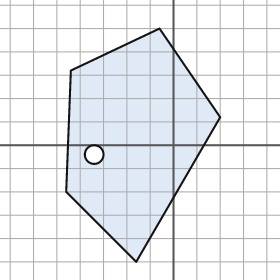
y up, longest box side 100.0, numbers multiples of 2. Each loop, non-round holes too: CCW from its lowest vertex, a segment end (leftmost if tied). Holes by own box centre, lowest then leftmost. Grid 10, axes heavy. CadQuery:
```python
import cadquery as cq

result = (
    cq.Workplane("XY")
    .moveTo(-16.0, -50.0)
    .lineTo(20.0, 12.0)
    .lineTo(-6.0, 50.0)
    .lineTo(-44.0, 32.0)
    .lineTo(-46.0, -20.0)
    .close()
    .moveTo(-34.0, -4.0)
    .circle(4.0)
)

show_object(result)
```